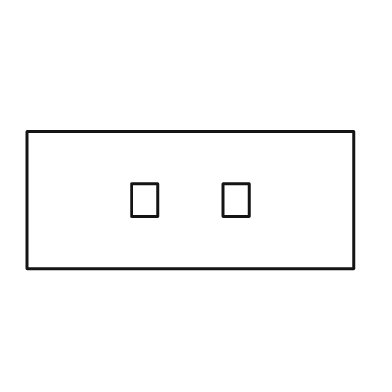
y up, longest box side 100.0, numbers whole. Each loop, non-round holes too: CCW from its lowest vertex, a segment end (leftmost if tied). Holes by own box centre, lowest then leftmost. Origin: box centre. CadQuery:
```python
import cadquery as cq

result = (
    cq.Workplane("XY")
    .moveTo(-50.0, -21.0)
    .lineTo(50.0, -21.0)
    .lineTo(50.0, 21.0)
    .lineTo(-50.0, 21.0)
    .close()
    .moveTo(-18.0, -5.0)
    .lineTo(-10.0, -5.0)
    .lineTo(-10.0, 5.0)
    .lineTo(-18.0, 5.0)
    .close()
    .moveTo(10.0, -5.0)
    .lineTo(18.0, -5.0)
    .lineTo(18.0, 5.0)
    .lineTo(10.0, 5.0)
    .close()
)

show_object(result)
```